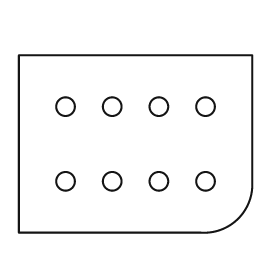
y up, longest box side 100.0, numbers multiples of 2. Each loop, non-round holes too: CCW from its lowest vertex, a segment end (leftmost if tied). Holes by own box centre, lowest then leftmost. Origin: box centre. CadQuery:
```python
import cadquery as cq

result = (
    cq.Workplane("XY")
    .moveTo(-50.0, -38.0)
    .lineTo(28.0, -38.0)
    .threePointArc((44.0, -32.0), (50.0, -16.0))
    .lineTo(50.0, 38.0)
    .lineTo(-50.0, 38.0)
    .close()
    .moveTo(-30.0, -16.0)
    .circle(4.0)
    .moveTo(-10.0, -16.0)
    .circle(4.0)
    .moveTo(10.0, -16.0)
    .circle(4.0)
    .moveTo(30.0, -16.0)
    .circle(4.0)
    .moveTo(-30.0, 16.0)
    .circle(4.0)
    .moveTo(-10.0, 16.0)
    .circle(4.0)
    .moveTo(10.0, 16.0)
    .circle(4.0)
    .moveTo(30.0, 16.0)
    .circle(4.0)
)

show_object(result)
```